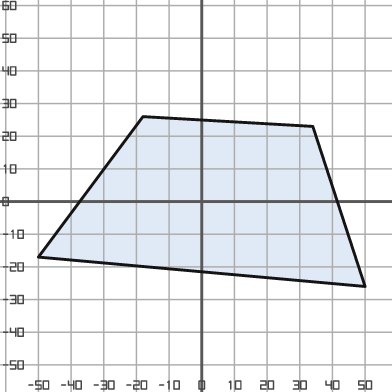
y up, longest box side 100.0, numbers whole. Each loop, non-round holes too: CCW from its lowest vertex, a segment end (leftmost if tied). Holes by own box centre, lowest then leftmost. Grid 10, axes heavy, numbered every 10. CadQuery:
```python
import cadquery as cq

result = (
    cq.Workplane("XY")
    .moveTo(50.0, -26.0)
    .lineTo(34.0, 23.0)
    .lineTo(-18.0, 26.0)
    .lineTo(-50.0, -17.0)
    .close()
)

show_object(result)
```